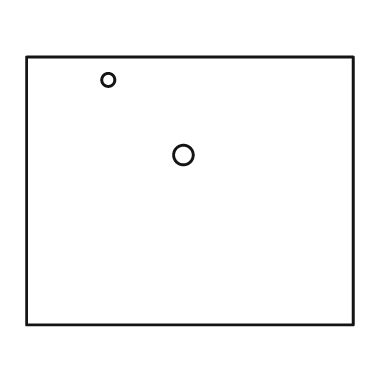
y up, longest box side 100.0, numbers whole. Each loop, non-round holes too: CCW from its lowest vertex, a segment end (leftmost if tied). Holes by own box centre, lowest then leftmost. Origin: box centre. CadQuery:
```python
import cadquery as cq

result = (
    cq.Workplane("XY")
    .moveTo(-50.0, -41.0)
    .lineTo(50.0, -41.0)
    .lineTo(50.0, 41.0)
    .lineTo(-50.0, 41.0)
    .close()
    .moveTo(-2.0, 11.0)
    .circle(3.0)
    .moveTo(-25.0, 34.0)
    .circle(2.0)
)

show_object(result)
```